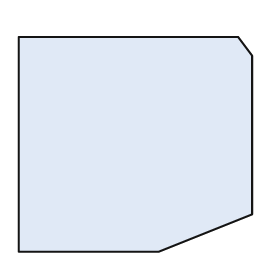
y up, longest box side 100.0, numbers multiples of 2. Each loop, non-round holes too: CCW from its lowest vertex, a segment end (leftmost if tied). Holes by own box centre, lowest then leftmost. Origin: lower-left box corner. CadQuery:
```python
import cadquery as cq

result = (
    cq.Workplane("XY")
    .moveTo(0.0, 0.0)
    .lineTo(60.0, 0.0)
    .lineTo(100.0, 16.0)
    .lineTo(100.0, 84.0)
    .lineTo(94.0, 92.0)
    .lineTo(0.0, 92.0)
    .close()
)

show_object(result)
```